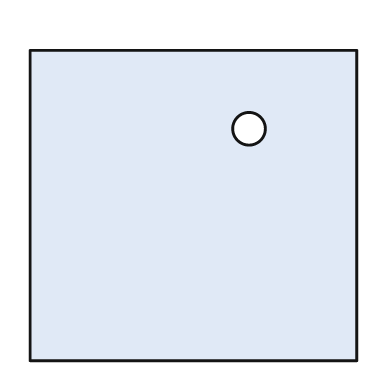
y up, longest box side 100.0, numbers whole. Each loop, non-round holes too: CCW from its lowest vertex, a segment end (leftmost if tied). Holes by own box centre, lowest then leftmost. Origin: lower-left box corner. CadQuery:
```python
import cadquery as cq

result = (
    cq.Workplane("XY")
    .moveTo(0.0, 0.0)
    .lineTo(100.0, 0.0)
    .lineTo(100.0, 95.0)
    .lineTo(0.0, 95.0)
    .close()
    .moveTo(67.0, 71.0)
    .circle(5.0)
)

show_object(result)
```